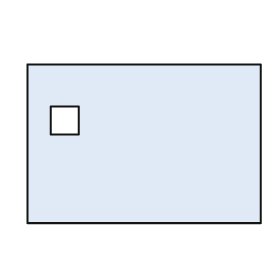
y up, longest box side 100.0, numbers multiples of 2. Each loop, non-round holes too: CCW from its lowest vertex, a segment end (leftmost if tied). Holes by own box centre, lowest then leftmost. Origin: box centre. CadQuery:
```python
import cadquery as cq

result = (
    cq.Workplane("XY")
    .moveTo(-50.0, -34.0)
    .lineTo(50.0, -34.0)
    .lineTo(50.0, 34.0)
    .lineTo(-50.0, 34.0)
    .close()
    .moveTo(-40.0, 4.0)
    .lineTo(-28.0, 4.0)
    .lineTo(-28.0, 16.0)
    .lineTo(-40.0, 16.0)
    .close()
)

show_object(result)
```